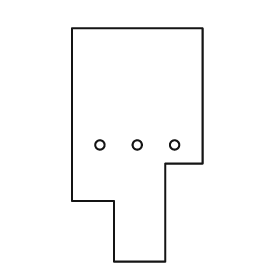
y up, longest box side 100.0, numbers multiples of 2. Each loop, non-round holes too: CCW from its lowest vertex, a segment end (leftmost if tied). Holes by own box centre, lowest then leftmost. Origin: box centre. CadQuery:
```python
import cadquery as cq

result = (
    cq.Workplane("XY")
    .moveTo(-10.0, -50.0)
    .lineTo(12.0, -50.0)
    .lineTo(12.0, -8.0)
    .lineTo(28.0, -8.0)
    .lineTo(28.0, 50.0)
    .lineTo(-28.0, 50.0)
    .lineTo(-28.0, -24.0)
    .lineTo(-10.0, -24.0)
    .close()
    .moveTo(-16.0, 0.0)
    .circle(2.0)
    .moveTo(0.0, 0.0)
    .circle(2.0)
    .moveTo(16.0, 0.0)
    .circle(2.0)
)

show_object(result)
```